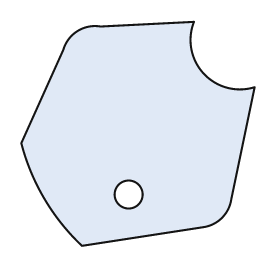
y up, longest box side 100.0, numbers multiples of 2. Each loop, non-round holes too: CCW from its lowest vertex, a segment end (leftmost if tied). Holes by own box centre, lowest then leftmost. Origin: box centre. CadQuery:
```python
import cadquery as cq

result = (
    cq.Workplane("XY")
    .moveTo(-24.0, -48.0)
    .lineTo(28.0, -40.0)
    .threePointArc((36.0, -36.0), (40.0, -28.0))
    .lineTo(50.0, 20.0)
    .threePointArc((28.0, 26.0), (24.0, 48.0))
    .lineTo(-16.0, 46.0)
    .threePointArc((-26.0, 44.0), (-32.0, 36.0))
    .lineTo(-50.0, -4.0)
    .threePointArc((-40.0, -28.0), (-24.0, -48.0))
    .close()
    .moveTo(-4.0, -26.0)
    .circle(6.0)
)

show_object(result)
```